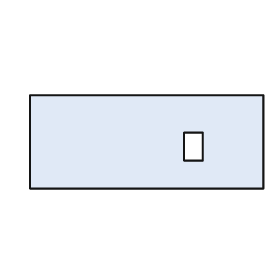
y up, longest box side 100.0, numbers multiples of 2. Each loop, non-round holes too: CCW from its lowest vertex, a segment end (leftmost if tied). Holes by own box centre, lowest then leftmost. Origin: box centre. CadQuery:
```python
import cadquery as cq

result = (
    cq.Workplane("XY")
    .moveTo(-50.0, -20.0)
    .lineTo(50.0, -20.0)
    .lineTo(50.0, 20.0)
    .lineTo(-50.0, 20.0)
    .close()
    .moveTo(16.0, -8.0)
    .lineTo(24.0, -8.0)
    .lineTo(24.0, 4.0)
    .lineTo(16.0, 4.0)
    .close()
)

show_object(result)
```